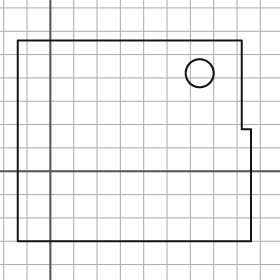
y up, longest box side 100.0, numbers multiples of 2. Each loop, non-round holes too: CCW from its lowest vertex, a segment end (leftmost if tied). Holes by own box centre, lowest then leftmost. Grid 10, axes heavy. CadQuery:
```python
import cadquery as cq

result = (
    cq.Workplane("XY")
    .moveTo(-14.0, -30.0)
    .lineTo(86.0, -30.0)
    .lineTo(86.0, 18.0)
    .lineTo(82.0, 18.0)
    .lineTo(82.0, 56.0)
    .lineTo(-14.0, 56.0)
    .close()
    .moveTo(64.0, 42.0)
    .circle(6.0)
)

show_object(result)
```